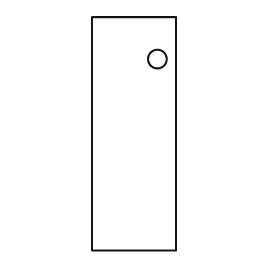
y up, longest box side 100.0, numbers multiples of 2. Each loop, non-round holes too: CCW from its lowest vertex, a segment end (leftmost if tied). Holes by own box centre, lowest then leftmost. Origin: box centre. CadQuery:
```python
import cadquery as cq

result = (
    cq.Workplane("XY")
    .moveTo(-18.0, -50.0)
    .lineTo(18.0, -50.0)
    .lineTo(18.0, 50.0)
    .lineTo(-18.0, 50.0)
    .close()
    .moveTo(10.0, 32.0)
    .circle(4.0)
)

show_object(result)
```